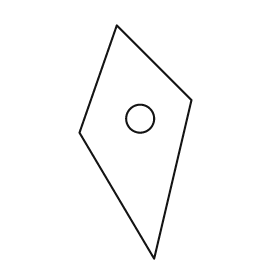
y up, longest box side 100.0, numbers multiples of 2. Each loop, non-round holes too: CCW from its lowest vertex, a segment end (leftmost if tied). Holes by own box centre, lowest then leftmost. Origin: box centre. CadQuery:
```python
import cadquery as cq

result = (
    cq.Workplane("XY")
    .moveTo(8.0, -50.0)
    .lineTo(24.0, 18.0)
    .lineTo(-8.0, 50.0)
    .lineTo(-24.0, 4.0)
    .close()
    .moveTo(2.0, 10.0)
    .circle(6.0)
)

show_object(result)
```